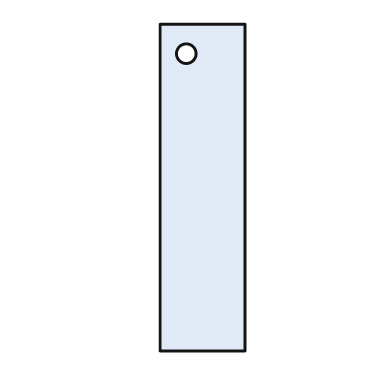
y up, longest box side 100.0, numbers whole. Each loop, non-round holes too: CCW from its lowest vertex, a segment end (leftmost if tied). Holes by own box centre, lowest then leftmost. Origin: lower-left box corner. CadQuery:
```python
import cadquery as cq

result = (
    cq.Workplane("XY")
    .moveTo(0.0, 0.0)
    .lineTo(26.0, 0.0)
    .lineTo(26.0, 100.0)
    .lineTo(0.0, 100.0)
    .close()
    .moveTo(8.0, 91.0)
    .circle(3.0)
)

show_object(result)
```